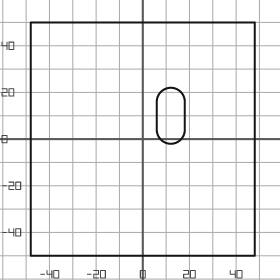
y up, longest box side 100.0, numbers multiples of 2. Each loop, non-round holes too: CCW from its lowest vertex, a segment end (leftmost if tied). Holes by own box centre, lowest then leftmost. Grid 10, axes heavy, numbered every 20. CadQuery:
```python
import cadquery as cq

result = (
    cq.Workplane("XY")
    .moveTo(-48.0, -50.0)
    .lineTo(48.0, -50.0)
    .lineTo(48.0, 50.0)
    .lineTo(-48.0, 50.0)
    .close()
    .moveTo(6.0, 4.0)
    .threePointArc((12.0, -2.0), (18.0, 4.0))
    .lineTo(18.0, 16.0)
    .threePointArc((12.0, 22.0), (6.0, 16.0))
    .close()
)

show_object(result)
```